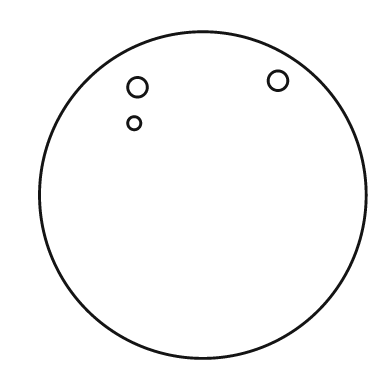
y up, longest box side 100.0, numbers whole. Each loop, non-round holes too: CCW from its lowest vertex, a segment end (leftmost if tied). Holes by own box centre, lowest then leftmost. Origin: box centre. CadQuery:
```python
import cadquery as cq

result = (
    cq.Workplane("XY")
    .moveTo(0.0, 0.0)
    .circle(50.0)
    .moveTo(-21.0, 22.0)
    .circle(2.0)
    .moveTo(-20.0, 33.0)
    .circle(3.0)
    .moveTo(23.0, 35.0)
    .circle(3.0)
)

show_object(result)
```